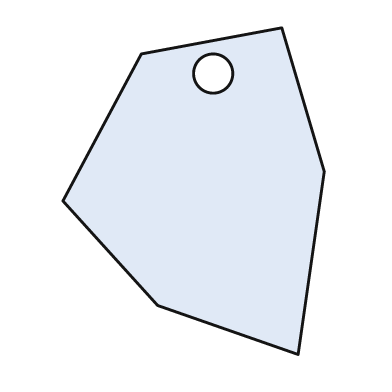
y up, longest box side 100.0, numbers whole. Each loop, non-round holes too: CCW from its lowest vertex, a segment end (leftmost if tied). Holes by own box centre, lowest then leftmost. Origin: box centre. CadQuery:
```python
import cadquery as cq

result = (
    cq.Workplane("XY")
    .moveTo(32.0, -50.0)
    .lineTo(40.0, 6.0)
    .lineTo(27.0, 50.0)
    .lineTo(-16.0, 42.0)
    .lineTo(-40.0, -3.0)
    .lineTo(-11.0, -35.0)
    .close()
    .moveTo(6.0, 36.0)
    .circle(6.0)
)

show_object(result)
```